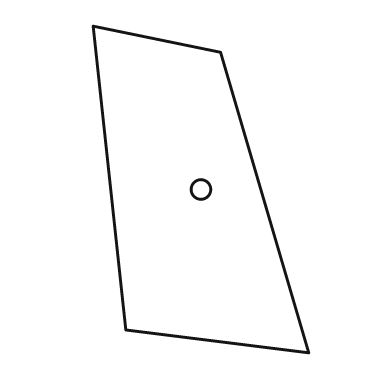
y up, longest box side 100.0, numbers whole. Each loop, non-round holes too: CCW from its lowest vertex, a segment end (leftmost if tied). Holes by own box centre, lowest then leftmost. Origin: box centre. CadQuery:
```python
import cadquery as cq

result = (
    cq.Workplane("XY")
    .moveTo(33.0, -50.0)
    .lineTo(6.0, 42.0)
    .lineTo(-33.0, 50.0)
    .lineTo(-23.0, -43.0)
    .close()
    .moveTo(0.0, 0.0)
    .circle(3.0)
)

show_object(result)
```